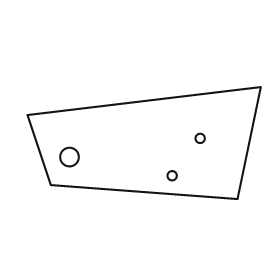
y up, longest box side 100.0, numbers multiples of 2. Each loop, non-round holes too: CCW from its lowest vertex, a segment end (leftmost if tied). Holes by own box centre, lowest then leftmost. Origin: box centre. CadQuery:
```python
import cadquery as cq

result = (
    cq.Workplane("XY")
    .moveTo(40.0, -24.0)
    .lineTo(50.0, 24.0)
    .lineTo(-50.0, 12.0)
    .lineTo(-40.0, -18.0)
    .close()
    .moveTo(12.0, -14.0)
    .circle(2.0)
    .moveTo(-32.0, -6.0)
    .circle(4.0)
    .moveTo(24.0, 2.0)
    .circle(2.0)
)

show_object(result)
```